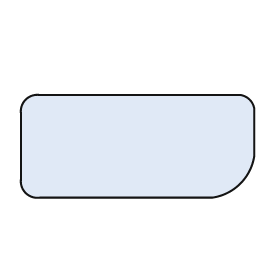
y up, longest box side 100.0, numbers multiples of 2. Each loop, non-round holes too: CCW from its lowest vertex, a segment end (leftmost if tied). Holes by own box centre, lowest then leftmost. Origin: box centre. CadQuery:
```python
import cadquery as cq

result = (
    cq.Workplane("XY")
    .moveTo(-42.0, -22.0)
    .lineTo(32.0, -22.0)
    .threePointArc((44.0, -16.0), (50.0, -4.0))
    .lineTo(50.0, 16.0)
    .threePointArc((48.0, 20.0), (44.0, 22.0))
    .lineTo(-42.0, 22.0)
    .threePointArc((-48.0, 20.0), (-50.0, 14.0))
    .lineTo(-50.0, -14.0)
    .threePointArc((-48.0, -20.0), (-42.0, -22.0))
    .close()
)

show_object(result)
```